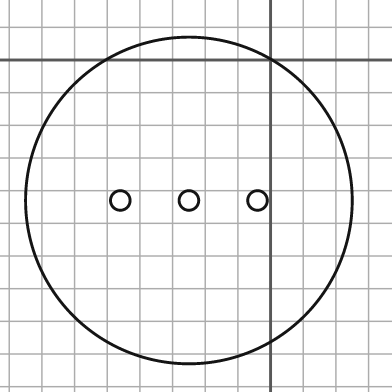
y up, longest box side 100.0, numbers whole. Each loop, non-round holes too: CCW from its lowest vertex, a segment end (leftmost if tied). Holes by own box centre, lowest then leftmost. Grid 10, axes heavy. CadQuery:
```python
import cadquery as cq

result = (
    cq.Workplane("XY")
    .moveTo(-25.0, -43.0)
    .circle(50.0)
    .moveTo(-46.0, -43.0)
    .circle(3.0)
    .moveTo(-25.0, -43.0)
    .circle(3.0)
    .moveTo(-4.0, -43.0)
    .circle(3.0)
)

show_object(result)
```